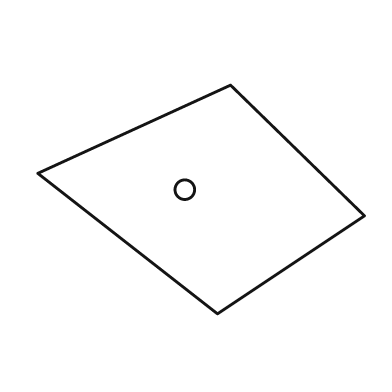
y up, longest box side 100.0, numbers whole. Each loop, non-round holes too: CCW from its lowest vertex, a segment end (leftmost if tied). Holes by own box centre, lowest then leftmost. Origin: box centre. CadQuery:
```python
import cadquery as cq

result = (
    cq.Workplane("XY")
    .moveTo(5.0, -35.0)
    .lineTo(50.0, -5.0)
    .lineTo(9.0, 35.0)
    .lineTo(-50.0, 8.0)
    .close()
    .moveTo(-5.0, 3.0)
    .circle(3.0)
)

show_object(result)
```